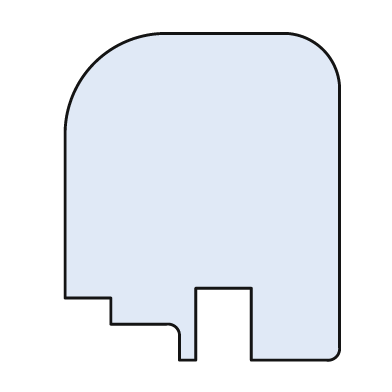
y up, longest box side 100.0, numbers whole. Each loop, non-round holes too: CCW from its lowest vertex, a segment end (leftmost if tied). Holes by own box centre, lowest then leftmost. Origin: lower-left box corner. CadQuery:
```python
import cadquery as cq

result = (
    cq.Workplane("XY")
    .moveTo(35.0, 0.0)
    .lineTo(40.0, 0.0)
    .lineTo(40.0, 22.0)
    .lineTo(57.0, 22.0)
    .lineTo(57.0, 0.0)
    .lineTo(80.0, 0.0)
    .threePointArc((83.0, 1.0), (84.0, 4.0))
    .lineTo(84.0, 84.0)
    .threePointArc((79.0, 95.0), (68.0, 100.0))
    .lineTo(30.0, 100.0)
    .threePointArc((9.0, 91.0), (0.0, 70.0))
    .lineTo(0.0, 19.0)
    .lineTo(14.0, 19.0)
    .lineTo(14.0, 11.0)
    .lineTo(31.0, 11.0)
    .threePointArc((34.0, 10.0), (35.0, 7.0))
    .close()
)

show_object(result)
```